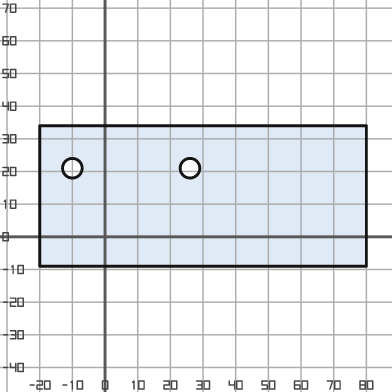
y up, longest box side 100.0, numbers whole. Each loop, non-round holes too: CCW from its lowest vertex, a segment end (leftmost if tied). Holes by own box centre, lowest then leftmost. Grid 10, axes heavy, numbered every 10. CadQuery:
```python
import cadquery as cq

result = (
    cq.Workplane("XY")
    .moveTo(-20.0, -9.0)
    .lineTo(80.0, -9.0)
    .lineTo(80.0, 34.0)
    .lineTo(-20.0, 34.0)
    .close()
    .moveTo(-10.0, 21.0)
    .circle(3.0)
    .moveTo(26.0, 21.0)
    .circle(3.0)
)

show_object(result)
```